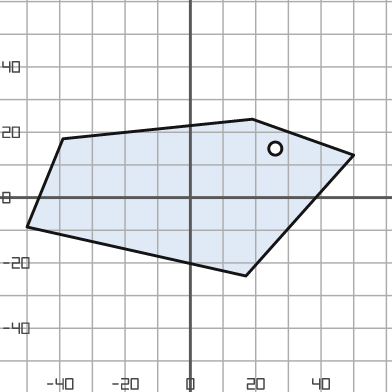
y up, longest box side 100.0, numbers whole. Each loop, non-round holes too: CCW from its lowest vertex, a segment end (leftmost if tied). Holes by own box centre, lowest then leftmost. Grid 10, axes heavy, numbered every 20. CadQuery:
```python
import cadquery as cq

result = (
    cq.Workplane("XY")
    .moveTo(17.0, -24.0)
    .lineTo(50.0, 13.0)
    .lineTo(19.0, 24.0)
    .lineTo(-39.0, 18.0)
    .lineTo(-50.0, -9.0)
    .close()
    .moveTo(26.0, 15.0)
    .circle(2.0)
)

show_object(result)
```